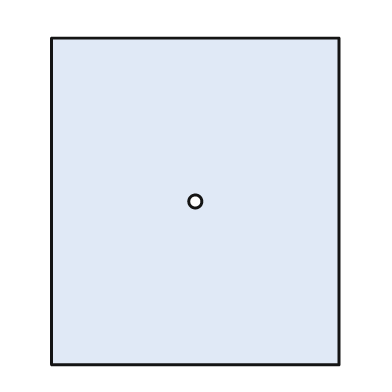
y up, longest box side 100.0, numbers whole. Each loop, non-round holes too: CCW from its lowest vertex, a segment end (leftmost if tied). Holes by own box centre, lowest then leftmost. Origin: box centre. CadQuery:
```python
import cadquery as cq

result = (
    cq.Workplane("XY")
    .moveTo(-44.0, -50.0)
    .lineTo(44.0, -50.0)
    .lineTo(44.0, 50.0)
    .lineTo(-44.0, 50.0)
    .close()
    .moveTo(0.0, 0.0)
    .circle(2.0)
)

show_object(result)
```